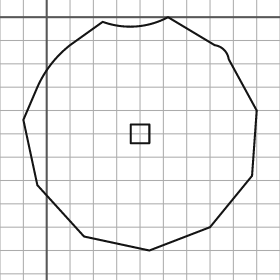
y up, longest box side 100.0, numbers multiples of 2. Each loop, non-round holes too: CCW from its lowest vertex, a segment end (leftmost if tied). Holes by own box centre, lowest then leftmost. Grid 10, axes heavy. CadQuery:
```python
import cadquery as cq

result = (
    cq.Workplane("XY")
    .moveTo(44.0, -100.0)
    .lineTo(70.0, -90.0)
    .lineTo(88.0, -68.0)
    .lineTo(90.0, -40.0)
    .lineTo(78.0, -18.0)
    .threePointArc((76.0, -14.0), (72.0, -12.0))
    .lineTo(52.0, 0.0)
    .threePointArc((38.0, -4.0), (24.0, -2.0))
    .lineTo(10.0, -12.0)
    .threePointArc((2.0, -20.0), (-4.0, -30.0))
    .lineTo(-10.0, -44.0)
    .lineTo(-4.0, -72.0)
    .lineTo(16.0, -94.0)
    .close()
    .moveTo(36.0, -54.0)
    .lineTo(44.0, -54.0)
    .lineTo(44.0, -46.0)
    .lineTo(36.0, -46.0)
    .close()
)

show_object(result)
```